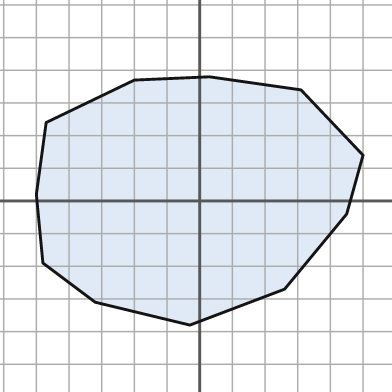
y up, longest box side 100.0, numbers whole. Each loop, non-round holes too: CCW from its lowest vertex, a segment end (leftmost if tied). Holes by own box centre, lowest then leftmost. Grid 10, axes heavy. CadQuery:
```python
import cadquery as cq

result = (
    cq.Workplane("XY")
    .moveTo(-3.0, -38.0)
    .lineTo(26.0, -27.0)
    .lineTo(45.0, -4.0)
    .lineTo(50.0, 14.0)
    .lineTo(31.0, 34.0)
    .lineTo(3.0, 38.0)
    .lineTo(-20.0, 37.0)
    .lineTo(-47.0, 24.0)
    .lineTo(-50.0, 2.0)
    .lineTo(-48.0, -19.0)
    .lineTo(-32.0, -31.0)
    .close()
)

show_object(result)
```